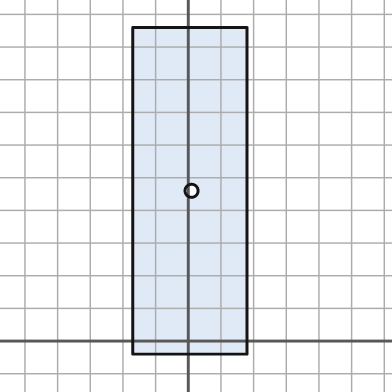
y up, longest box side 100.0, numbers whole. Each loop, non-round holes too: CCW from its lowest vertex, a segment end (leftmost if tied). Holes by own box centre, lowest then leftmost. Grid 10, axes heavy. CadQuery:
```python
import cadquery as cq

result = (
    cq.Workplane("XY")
    .moveTo(-17.0, -4.0)
    .lineTo(18.0, -4.0)
    .lineTo(18.0, 96.0)
    .lineTo(-17.0, 96.0)
    .close()
    .moveTo(1.0, 46.0)
    .circle(2.0)
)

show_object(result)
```